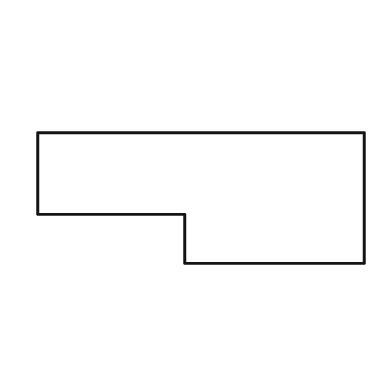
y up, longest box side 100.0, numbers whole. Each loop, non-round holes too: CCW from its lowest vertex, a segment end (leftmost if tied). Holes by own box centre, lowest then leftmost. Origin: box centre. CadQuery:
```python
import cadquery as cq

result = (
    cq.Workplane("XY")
    .moveTo(-5.0, -20.0)
    .lineTo(50.0, -20.0)
    .lineTo(50.0, 20.0)
    .lineTo(-50.0, 20.0)
    .lineTo(-50.0, -5.0)
    .lineTo(-5.0, -5.0)
    .close()
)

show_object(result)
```